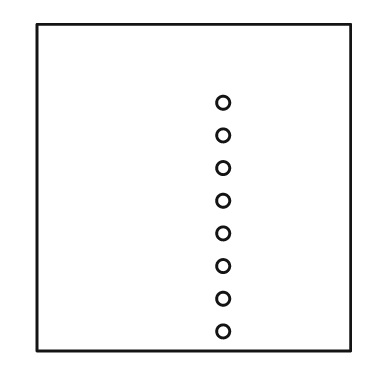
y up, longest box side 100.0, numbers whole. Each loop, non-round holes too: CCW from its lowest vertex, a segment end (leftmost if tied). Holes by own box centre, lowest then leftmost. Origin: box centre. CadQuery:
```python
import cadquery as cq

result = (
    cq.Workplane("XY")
    .moveTo(-48.0, -50.0)
    .lineTo(48.0, -50.0)
    .lineTo(48.0, 50.0)
    .lineTo(-48.0, 50.0)
    .close()
    .moveTo(9.0, -44.0)
    .circle(2.0)
    .moveTo(9.0, -34.0)
    .circle(2.0)
    .moveTo(9.0, -24.0)
    .circle(2.0)
    .moveTo(9.0, -14.0)
    .circle(2.0)
    .moveTo(9.0, -4.0)
    .circle(2.0)
    .moveTo(9.0, 6.0)
    .circle(2.0)
    .moveTo(9.0, 16.0)
    .circle(2.0)
    .moveTo(9.0, 26.0)
    .circle(2.0)
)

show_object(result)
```